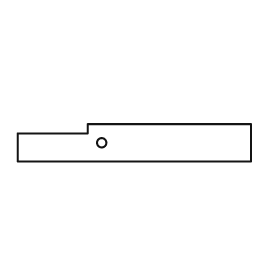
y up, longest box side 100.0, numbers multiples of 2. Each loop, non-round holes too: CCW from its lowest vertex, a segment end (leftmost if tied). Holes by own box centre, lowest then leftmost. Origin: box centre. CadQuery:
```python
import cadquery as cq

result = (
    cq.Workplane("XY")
    .moveTo(-50.0, -8.0)
    .lineTo(50.0, -8.0)
    .lineTo(50.0, 8.0)
    .lineTo(-20.0, 8.0)
    .lineTo(-20.0, 4.0)
    .lineTo(-50.0, 4.0)
    .close()
    .moveTo(-14.0, 0.0)
    .circle(2.0)
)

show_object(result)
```